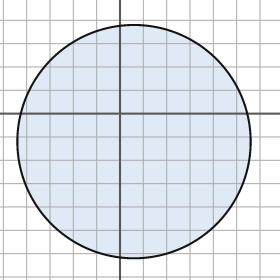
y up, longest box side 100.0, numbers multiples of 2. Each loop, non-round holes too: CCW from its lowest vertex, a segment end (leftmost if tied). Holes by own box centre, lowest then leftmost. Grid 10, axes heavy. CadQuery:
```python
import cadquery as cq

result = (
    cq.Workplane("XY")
    .moveTo(6.0, -12.0)
    .circle(50.0)
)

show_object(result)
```